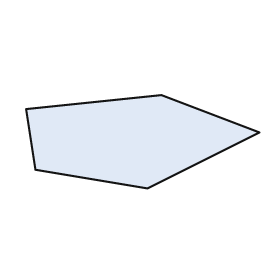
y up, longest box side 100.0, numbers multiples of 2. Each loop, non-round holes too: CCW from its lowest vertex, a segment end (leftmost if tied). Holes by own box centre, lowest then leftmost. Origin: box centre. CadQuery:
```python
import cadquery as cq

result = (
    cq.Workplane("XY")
    .moveTo(2.0, -20.0)
    .lineTo(50.0, 4.0)
    .lineTo(8.0, 20.0)
    .lineTo(-50.0, 14.0)
    .lineTo(-46.0, -12.0)
    .close()
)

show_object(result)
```